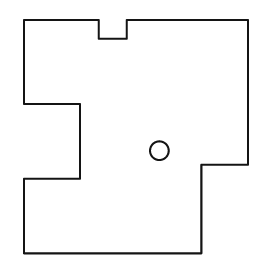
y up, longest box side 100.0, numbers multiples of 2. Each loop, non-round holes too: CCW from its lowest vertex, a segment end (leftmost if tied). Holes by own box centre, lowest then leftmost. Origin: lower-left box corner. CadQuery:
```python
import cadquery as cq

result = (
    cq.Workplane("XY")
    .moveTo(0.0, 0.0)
    .lineTo(76.0, 0.0)
    .lineTo(76.0, 38.0)
    .lineTo(96.0, 38.0)
    .lineTo(96.0, 100.0)
    .lineTo(44.0, 100.0)
    .lineTo(44.0, 92.0)
    .lineTo(32.0, 92.0)
    .lineTo(32.0, 100.0)
    .lineTo(0.0, 100.0)
    .lineTo(0.0, 64.0)
    .lineTo(24.0, 64.0)
    .lineTo(24.0, 32.0)
    .lineTo(0.0, 32.0)
    .close()
    .moveTo(58.0, 44.0)
    .circle(4.0)
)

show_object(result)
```